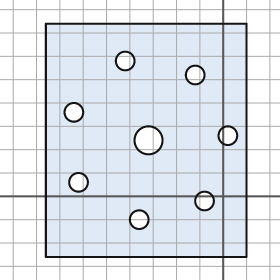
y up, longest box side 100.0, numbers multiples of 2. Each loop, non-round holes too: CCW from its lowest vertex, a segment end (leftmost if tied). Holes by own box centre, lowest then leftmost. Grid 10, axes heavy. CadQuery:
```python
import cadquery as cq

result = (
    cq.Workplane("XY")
    .moveTo(-76.0, -26.0)
    .lineTo(10.0, -26.0)
    .lineTo(10.0, 74.0)
    .lineTo(-76.0, 74.0)
    .close()
    .moveTo(-36.0, -10.0)
    .circle(4.0)
    .moveTo(-8.0, -2.0)
    .circle(4.0)
    .moveTo(-62.0, 6.0)
    .circle(4.0)
    .moveTo(-32.0, 24.0)
    .circle(6.0)
    .moveTo(2.0, 26.0)
    .circle(4.0)
    .moveTo(-64.0, 36.0)
    .circle(4.0)
    .moveTo(-12.0, 52.0)
    .circle(4.0)
    .moveTo(-42.0, 58.0)
    .circle(4.0)
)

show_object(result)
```